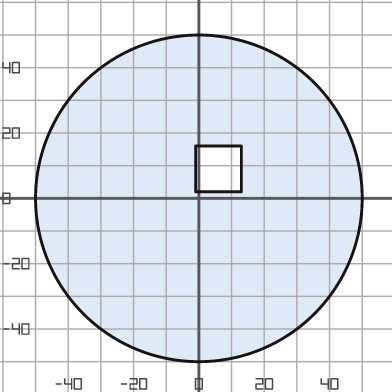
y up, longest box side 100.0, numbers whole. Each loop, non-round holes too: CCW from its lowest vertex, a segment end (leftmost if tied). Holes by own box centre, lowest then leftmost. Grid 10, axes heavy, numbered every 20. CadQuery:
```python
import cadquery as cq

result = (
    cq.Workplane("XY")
    .moveTo(0.0, 0.0)
    .circle(50.0)
    .moveTo(-1.0, 2.0)
    .lineTo(13.0, 2.0)
    .lineTo(13.0, 16.0)
    .lineTo(-1.0, 16.0)
    .close()
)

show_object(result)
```